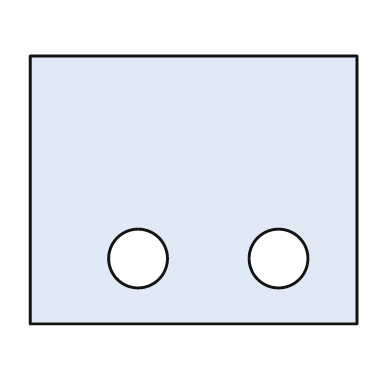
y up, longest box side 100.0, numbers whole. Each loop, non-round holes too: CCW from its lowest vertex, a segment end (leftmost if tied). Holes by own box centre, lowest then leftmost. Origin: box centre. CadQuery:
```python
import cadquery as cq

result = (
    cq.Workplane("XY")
    .moveTo(-50.0, -41.0)
    .lineTo(50.0, -41.0)
    .lineTo(50.0, 41.0)
    .lineTo(-50.0, 41.0)
    .close()
    .moveTo(-17.0, -21.0)
    .circle(9.0)
    .moveTo(26.0, -21.0)
    .circle(9.0)
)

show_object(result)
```